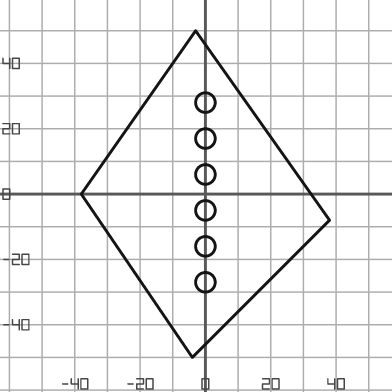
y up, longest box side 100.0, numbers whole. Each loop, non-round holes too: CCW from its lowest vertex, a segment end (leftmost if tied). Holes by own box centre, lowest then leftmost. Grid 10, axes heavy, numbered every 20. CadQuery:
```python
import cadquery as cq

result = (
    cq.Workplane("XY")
    .moveTo(-4.0, -50.0)
    .lineTo(38.0, -8.0)
    .lineTo(-3.0, 50.0)
    .lineTo(-38.0, 0.0)
    .close()
    .moveTo(0.0, -27.0)
    .circle(3.0)
    .moveTo(0.0, -16.0)
    .circle(3.0)
    .moveTo(0.0, -5.0)
    .circle(3.0)
    .moveTo(0.0, 6.0)
    .circle(3.0)
    .moveTo(0.0, 17.0)
    .circle(3.0)
    .moveTo(0.0, 28.0)
    .circle(3.0)
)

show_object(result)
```